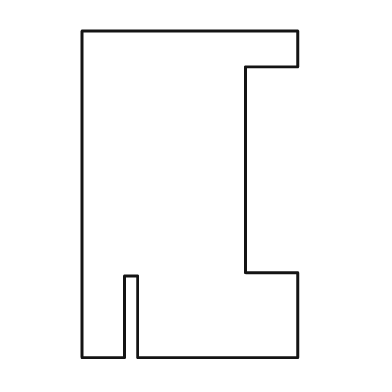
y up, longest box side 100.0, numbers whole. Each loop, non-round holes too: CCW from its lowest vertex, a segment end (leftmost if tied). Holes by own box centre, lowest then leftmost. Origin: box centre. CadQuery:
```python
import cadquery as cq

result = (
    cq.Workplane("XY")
    .moveTo(-33.0, -50.0)
    .lineTo(-20.0, -50.0)
    .lineTo(-20.0, -25.0)
    .lineTo(-16.0, -25.0)
    .lineTo(-16.0, -50.0)
    .lineTo(33.0, -50.0)
    .lineTo(33.0, -24.0)
    .lineTo(17.0, -24.0)
    .lineTo(17.0, 39.0)
    .lineTo(33.0, 39.0)
    .lineTo(33.0, 50.0)
    .lineTo(-33.0, 50.0)
    .close()
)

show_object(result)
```